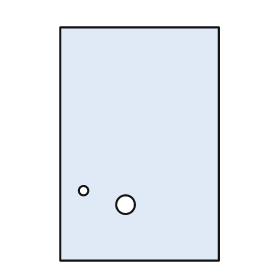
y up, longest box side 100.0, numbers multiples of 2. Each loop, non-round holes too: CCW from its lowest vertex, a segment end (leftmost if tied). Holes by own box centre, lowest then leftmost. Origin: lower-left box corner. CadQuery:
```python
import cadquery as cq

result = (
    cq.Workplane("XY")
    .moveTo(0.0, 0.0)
    .lineTo(68.0, 0.0)
    .lineTo(68.0, 100.0)
    .lineTo(0.0, 100.0)
    .close()
    .moveTo(28.0, 24.0)
    .circle(4.0)
    .moveTo(10.0, 30.0)
    .circle(2.0)
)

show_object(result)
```